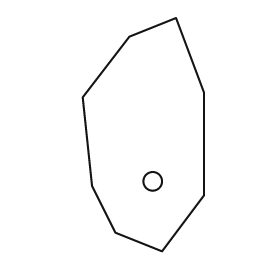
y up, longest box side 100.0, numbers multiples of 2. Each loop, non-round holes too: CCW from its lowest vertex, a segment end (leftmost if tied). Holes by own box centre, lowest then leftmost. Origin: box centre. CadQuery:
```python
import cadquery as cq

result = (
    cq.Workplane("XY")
    .moveTo(8.0, -50.0)
    .lineTo(26.0, -26.0)
    .lineTo(26.0, 18.0)
    .lineTo(14.0, 50.0)
    .lineTo(-6.0, 42.0)
    .lineTo(-26.0, 16.0)
    .lineTo(-22.0, -22.0)
    .lineTo(-12.0, -42.0)
    .close()
    .moveTo(4.0, -20.0)
    .circle(4.0)
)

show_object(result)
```